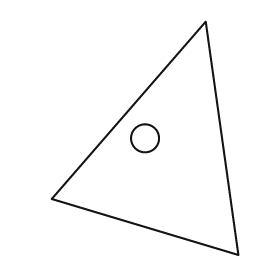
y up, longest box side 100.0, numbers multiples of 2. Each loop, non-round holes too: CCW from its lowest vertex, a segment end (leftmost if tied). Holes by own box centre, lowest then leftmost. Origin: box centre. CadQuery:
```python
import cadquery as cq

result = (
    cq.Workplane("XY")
    .moveTo(40.0, -50.0)
    .lineTo(26.0, 50.0)
    .lineTo(-40.0, -26.0)
    .close()
    .moveTo(0.0, 0.0)
    .circle(6.0)
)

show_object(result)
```